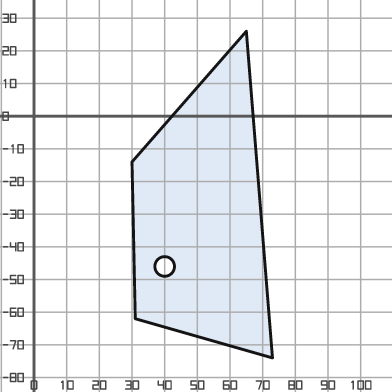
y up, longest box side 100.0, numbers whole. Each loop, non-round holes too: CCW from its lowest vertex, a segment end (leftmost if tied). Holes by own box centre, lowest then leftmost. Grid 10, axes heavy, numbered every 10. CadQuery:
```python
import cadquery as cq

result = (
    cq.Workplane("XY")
    .moveTo(73.0, -74.0)
    .lineTo(65.0, 26.0)
    .lineTo(30.0, -14.0)
    .lineTo(31.0, -62.0)
    .close()
    .moveTo(40.0, -46.0)
    .circle(3.0)
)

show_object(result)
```